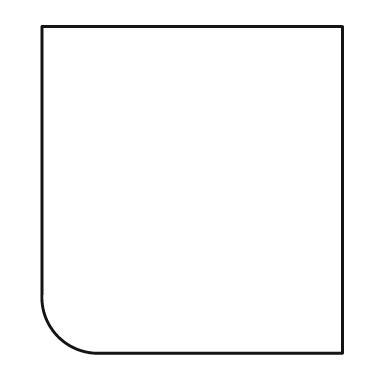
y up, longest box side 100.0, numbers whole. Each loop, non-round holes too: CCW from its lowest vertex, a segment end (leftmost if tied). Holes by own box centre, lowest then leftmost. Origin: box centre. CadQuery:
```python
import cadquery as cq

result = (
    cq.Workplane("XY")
    .moveTo(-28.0, -50.0)
    .lineTo(46.0, -50.0)
    .lineTo(46.0, 50.0)
    .lineTo(-46.0, 50.0)
    .lineTo(-46.0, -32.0)
    .threePointArc((-41.0, -45.0), (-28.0, -50.0))
    .close()
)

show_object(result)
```